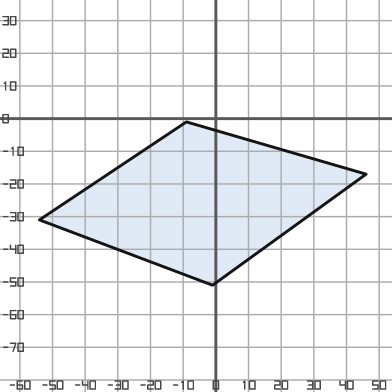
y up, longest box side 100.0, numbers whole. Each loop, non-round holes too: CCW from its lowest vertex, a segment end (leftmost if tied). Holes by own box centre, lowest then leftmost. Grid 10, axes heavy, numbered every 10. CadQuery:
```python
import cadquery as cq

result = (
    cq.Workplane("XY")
    .moveTo(-1.0, -51.0)
    .lineTo(46.0, -17.0)
    .lineTo(-9.0, -1.0)
    .lineTo(-54.0, -31.0)
    .close()
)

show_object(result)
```